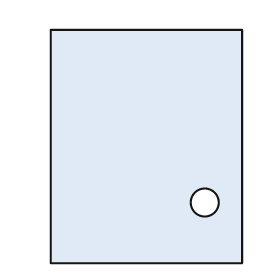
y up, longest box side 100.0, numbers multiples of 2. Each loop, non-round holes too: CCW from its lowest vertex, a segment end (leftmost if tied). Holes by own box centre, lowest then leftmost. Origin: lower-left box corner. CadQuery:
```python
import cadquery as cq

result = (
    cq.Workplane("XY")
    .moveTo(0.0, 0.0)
    .lineTo(82.0, 0.0)
    .lineTo(82.0, 100.0)
    .lineTo(0.0, 100.0)
    .close()
    .moveTo(66.0, 26.0)
    .circle(6.0)
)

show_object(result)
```